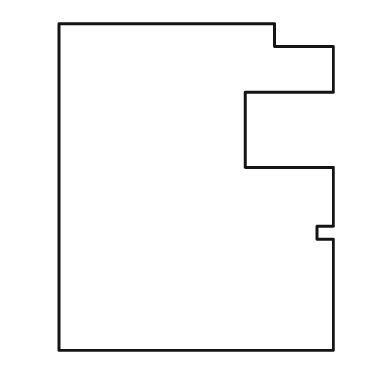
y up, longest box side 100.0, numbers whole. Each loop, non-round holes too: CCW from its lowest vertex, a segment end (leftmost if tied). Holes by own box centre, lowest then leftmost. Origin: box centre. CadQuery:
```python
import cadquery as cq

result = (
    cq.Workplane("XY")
    .moveTo(-42.0, -50.0)
    .lineTo(42.0, -50.0)
    .lineTo(42.0, -16.0)
    .lineTo(37.0, -16.0)
    .lineTo(37.0, -12.0)
    .lineTo(42.0, -12.0)
    .lineTo(42.0, 6.0)
    .lineTo(15.0, 6.0)
    .lineTo(15.0, 29.0)
    .lineTo(42.0, 29.0)
    .lineTo(42.0, 43.0)
    .lineTo(24.0, 43.0)
    .lineTo(24.0, 50.0)
    .lineTo(-42.0, 50.0)
    .close()
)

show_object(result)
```